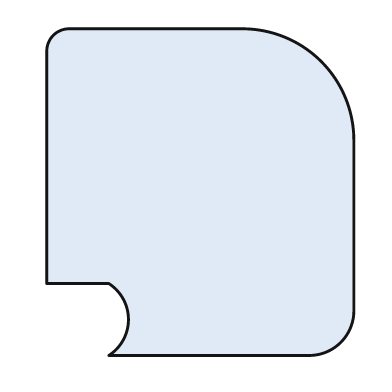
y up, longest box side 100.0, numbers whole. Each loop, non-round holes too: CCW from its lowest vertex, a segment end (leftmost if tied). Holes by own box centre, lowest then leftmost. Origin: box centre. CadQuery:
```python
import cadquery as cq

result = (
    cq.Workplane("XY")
    .moveTo(-28.0, -50.0)
    .lineTo(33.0, -50.0)
    .threePointArc((43.0, -46.0), (47.0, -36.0))
    .lineTo(47.0, 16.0)
    .threePointArc((37.0, 40.0), (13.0, 50.0))
    .lineTo(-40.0, 50.0)
    .threePointArc((-45.0, 48.0), (-47.0, 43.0))
    .lineTo(-47.0, -28.0)
    .lineTo(-28.0, -28.0)
    .threePointArc((-22.0, -39.0), (-28.0, -50.0))
    .close()
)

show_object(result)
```